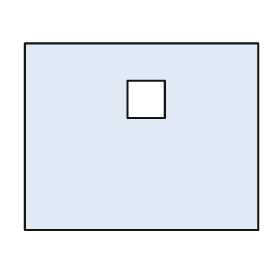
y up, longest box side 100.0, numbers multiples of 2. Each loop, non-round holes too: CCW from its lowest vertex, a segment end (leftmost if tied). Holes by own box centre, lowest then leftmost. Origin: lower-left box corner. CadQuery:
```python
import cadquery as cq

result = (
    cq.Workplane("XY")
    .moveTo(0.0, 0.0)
    .lineTo(100.0, 0.0)
    .lineTo(100.0, 80.0)
    .lineTo(0.0, 80.0)
    .close()
    .moveTo(44.0, 48.0)
    .lineTo(60.0, 48.0)
    .lineTo(60.0, 64.0)
    .lineTo(44.0, 64.0)
    .close()
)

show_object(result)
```